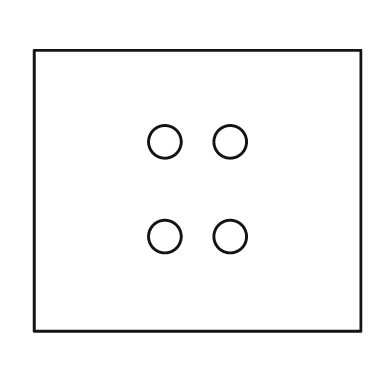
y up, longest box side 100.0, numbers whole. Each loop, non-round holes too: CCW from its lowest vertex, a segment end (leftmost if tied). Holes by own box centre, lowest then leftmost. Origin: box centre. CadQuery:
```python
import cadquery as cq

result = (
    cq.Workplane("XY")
    .moveTo(-50.0, -43.0)
    .lineTo(50.0, -43.0)
    .lineTo(50.0, 43.0)
    .lineTo(-50.0, 43.0)
    .close()
    .moveTo(-10.0, -14.0)
    .circle(5.0)
    .moveTo(10.0, -14.0)
    .circle(5.0)
    .moveTo(-10.0, 15.0)
    .circle(5.0)
    .moveTo(10.0, 15.0)
    .circle(5.0)
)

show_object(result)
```